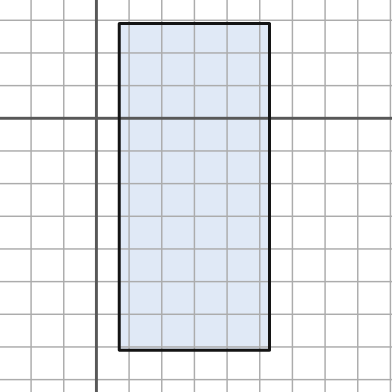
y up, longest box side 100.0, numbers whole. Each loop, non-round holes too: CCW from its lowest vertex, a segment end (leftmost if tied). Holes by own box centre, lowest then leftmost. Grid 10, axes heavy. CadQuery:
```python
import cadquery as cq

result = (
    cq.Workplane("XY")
    .moveTo(7.0, -71.0)
    .lineTo(53.0, -71.0)
    .lineTo(53.0, 29.0)
    .lineTo(7.0, 29.0)
    .close()
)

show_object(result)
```